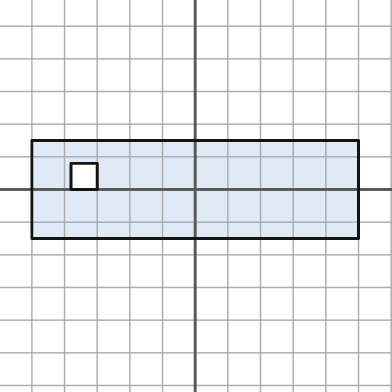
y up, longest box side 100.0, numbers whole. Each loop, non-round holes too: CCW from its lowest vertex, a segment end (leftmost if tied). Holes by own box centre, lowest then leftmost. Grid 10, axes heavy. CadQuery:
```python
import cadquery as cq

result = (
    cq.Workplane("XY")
    .moveTo(-50.0, -15.0)
    .lineTo(50.0, -15.0)
    .lineTo(50.0, 15.0)
    .lineTo(-50.0, 15.0)
    .close()
    .moveTo(-38.0, 0.0)
    .lineTo(-30.0, 0.0)
    .lineTo(-30.0, 8.0)
    .lineTo(-38.0, 8.0)
    .close()
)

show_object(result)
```